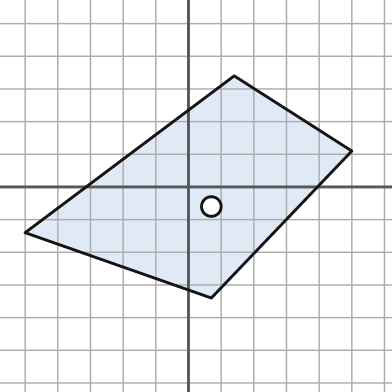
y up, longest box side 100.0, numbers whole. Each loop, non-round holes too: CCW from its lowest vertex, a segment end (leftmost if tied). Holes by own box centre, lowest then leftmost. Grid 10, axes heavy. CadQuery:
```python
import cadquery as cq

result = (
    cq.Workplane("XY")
    .moveTo(7.0, -34.0)
    .lineTo(50.0, 11.0)
    .lineTo(14.0, 34.0)
    .lineTo(-50.0, -14.0)
    .close()
    .moveTo(7.0, -6.0)
    .circle(3.0)
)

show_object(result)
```